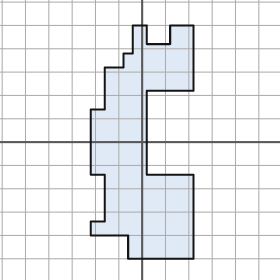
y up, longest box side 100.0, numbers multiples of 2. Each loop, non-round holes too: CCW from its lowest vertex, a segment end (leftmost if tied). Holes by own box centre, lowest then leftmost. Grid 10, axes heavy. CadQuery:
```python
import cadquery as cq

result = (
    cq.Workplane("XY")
    .moveTo(-6.0, -50.0)
    .lineTo(22.0, -50.0)
    .lineTo(22.0, -14.0)
    .lineTo(2.0, -14.0)
    .lineTo(2.0, 22.0)
    .lineTo(22.0, 22.0)
    .lineTo(22.0, 50.0)
    .lineTo(12.0, 50.0)
    .lineTo(12.0, 42.0)
    .lineTo(2.0, 42.0)
    .lineTo(2.0, 50.0)
    .lineTo(-4.0, 50.0)
    .lineTo(-4.0, 38.0)
    .lineTo(-8.0, 38.0)
    .lineTo(-8.0, 32.0)
    .lineTo(-16.0, 32.0)
    .lineTo(-16.0, 14.0)
    .lineTo(-22.0, 14.0)
    .lineTo(-22.0, -14.0)
    .lineTo(-16.0, -14.0)
    .lineTo(-16.0, -34.0)
    .lineTo(-22.0, -34.0)
    .lineTo(-22.0, -40.0)
    .lineTo(-6.0, -40.0)
    .close()
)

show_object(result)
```